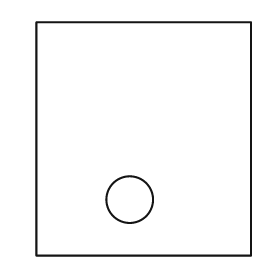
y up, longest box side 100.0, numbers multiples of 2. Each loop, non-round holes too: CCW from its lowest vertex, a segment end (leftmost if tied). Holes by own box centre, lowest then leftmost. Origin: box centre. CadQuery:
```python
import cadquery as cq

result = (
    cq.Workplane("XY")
    .moveTo(-46.0, -50.0)
    .lineTo(46.0, -50.0)
    .lineTo(46.0, 50.0)
    .lineTo(-46.0, 50.0)
    .close()
    .moveTo(-6.0, -26.0)
    .circle(10.0)
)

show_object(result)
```